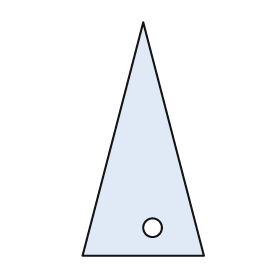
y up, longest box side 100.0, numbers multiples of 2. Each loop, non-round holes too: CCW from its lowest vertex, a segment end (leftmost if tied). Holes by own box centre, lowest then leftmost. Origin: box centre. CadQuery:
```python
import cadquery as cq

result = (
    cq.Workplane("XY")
    .moveTo(-26.0, -50.0)
    .lineTo(26.0, -50.0)
    .lineTo(0.0, 50.0)
    .close()
    .moveTo(4.0, -38.0)
    .circle(4.0)
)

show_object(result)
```